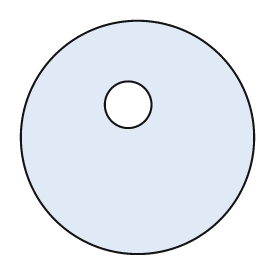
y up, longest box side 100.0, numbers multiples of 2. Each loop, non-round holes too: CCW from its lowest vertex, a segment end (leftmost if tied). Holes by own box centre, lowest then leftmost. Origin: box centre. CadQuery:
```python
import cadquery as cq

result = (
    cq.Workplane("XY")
    .moveTo(0.0, 0.0)
    .circle(50.0)
    .moveTo(-4.0, 14.0)
    .circle(10.0)
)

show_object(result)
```